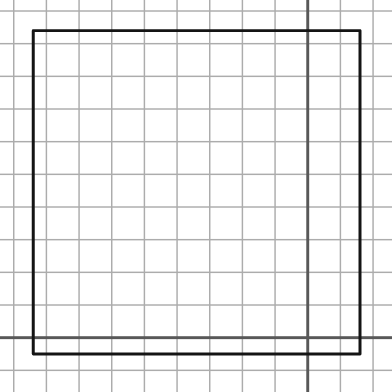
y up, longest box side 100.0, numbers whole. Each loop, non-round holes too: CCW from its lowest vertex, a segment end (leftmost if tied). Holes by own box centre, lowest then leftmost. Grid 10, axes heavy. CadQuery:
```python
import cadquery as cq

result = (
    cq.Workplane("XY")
    .moveTo(-84.0, -5.0)
    .lineTo(16.0, -5.0)
    .lineTo(16.0, 94.0)
    .lineTo(-84.0, 94.0)
    .close()
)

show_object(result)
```